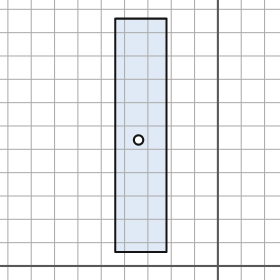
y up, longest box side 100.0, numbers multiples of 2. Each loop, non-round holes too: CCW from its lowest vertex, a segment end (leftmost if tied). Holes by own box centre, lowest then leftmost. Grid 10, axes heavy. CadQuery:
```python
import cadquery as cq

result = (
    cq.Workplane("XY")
    .moveTo(-44.0, 6.0)
    .lineTo(-22.0, 6.0)
    .lineTo(-22.0, 106.0)
    .lineTo(-44.0, 106.0)
    .close()
    .moveTo(-34.0, 54.0)
    .circle(2.0)
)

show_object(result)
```